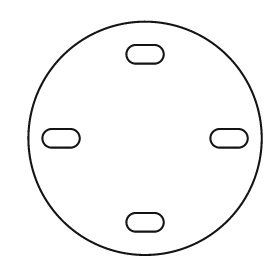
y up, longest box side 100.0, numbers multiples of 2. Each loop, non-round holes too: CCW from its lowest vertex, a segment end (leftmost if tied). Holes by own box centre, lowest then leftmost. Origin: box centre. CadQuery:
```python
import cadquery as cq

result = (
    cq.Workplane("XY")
    .moveTo(0.0, 0.0)
    .circle(50.0)
    .moveTo(-4.0, -40.0)
    .lineTo(4.0, -40.0)
    .threePointArc((8.0, -36.0), (4.0, -32.0))
    .lineTo(-4.0, -32.0)
    .threePointArc((-8.0, -36.0), (-4.0, -40.0))
    .close()
    .moveTo(-40.0, -4.0)
    .lineTo(-32.0, -4.0)
    .threePointArc((-28.0, 0.0), (-32.0, 4.0))
    .lineTo(-40.0, 4.0)
    .threePointArc((-44.0, 0.0), (-40.0, -4.0))
    .close()
    .moveTo(32.0, -4.0)
    .lineTo(40.0, -4.0)
    .threePointArc((44.0, 0.0), (40.0, 4.0))
    .lineTo(32.0, 4.0)
    .threePointArc((28.0, 0.0), (32.0, -4.0))
    .close()
    .moveTo(-4.0, 32.0)
    .lineTo(4.0, 32.0)
    .threePointArc((8.0, 36.0), (4.0, 40.0))
    .lineTo(-4.0, 40.0)
    .threePointArc((-8.0, 36.0), (-4.0, 32.0))
    .close()
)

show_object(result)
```